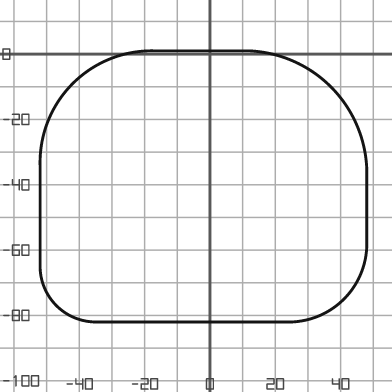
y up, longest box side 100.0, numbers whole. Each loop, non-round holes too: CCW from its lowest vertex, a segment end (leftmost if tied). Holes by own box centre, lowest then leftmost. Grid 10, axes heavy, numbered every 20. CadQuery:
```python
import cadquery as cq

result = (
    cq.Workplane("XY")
    .moveTo(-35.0, -82.0)
    .lineTo(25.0, -82.0)
    .threePointArc((41.0, -75.0), (48.0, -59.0))
    .lineTo(48.0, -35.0)
    .threePointArc((37.0, -10.0), (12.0, 1.0))
    .lineTo(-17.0, 1.0)
    .threePointArc((-42.0, -9.0), (-52.0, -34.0))
    .lineTo(-52.0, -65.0)
    .threePointArc((-47.0, -77.0), (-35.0, -82.0))
    .close()
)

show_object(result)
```